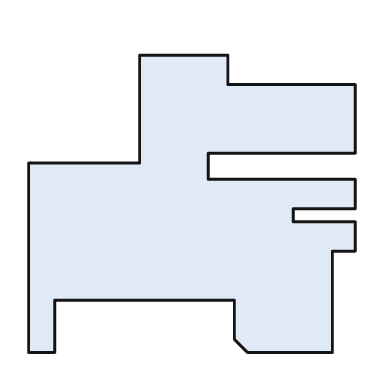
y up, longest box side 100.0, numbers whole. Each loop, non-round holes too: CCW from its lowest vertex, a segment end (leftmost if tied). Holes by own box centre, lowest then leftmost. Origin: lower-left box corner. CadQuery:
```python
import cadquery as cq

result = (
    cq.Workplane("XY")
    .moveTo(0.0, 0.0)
    .lineTo(8.0, 0.0)
    .lineTo(8.0, 16.0)
    .lineTo(63.0, 16.0)
    .lineTo(63.0, 4.0)
    .lineTo(67.0, 0.0)
    .lineTo(93.0, 0.0)
    .lineTo(93.0, 31.0)
    .lineTo(100.0, 31.0)
    .lineTo(100.0, 40.0)
    .lineTo(81.0, 40.0)
    .lineTo(81.0, 44.0)
    .lineTo(100.0, 44.0)
    .lineTo(100.0, 53.0)
    .lineTo(55.0, 53.0)
    .lineTo(55.0, 61.0)
    .lineTo(100.0, 61.0)
    .lineTo(100.0, 82.0)
    .lineTo(61.0, 82.0)
    .lineTo(61.0, 91.0)
    .lineTo(34.0, 91.0)
    .lineTo(34.0, 58.0)
    .lineTo(0.0, 58.0)
    .close()
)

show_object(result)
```